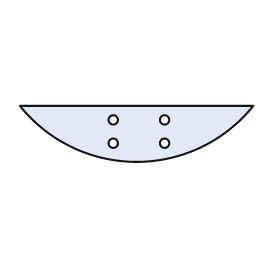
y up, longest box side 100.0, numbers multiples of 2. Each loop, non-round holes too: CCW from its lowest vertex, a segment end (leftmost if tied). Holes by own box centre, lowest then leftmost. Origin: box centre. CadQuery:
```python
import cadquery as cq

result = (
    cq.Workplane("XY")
    .moveTo(-50.0, 12.0)
    .threePointArc((0.0, -12.0), (50.0, 12.0))
    .close()
    .moveTo(-10.0, -4.0)
    .circle(2.0)
    .moveTo(12.0, -4.0)
    .circle(2.0)
    .moveTo(-10.0, 6.0)
    .circle(2.0)
    .moveTo(12.0, 6.0)
    .circle(2.0)
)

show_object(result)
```